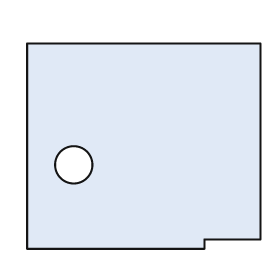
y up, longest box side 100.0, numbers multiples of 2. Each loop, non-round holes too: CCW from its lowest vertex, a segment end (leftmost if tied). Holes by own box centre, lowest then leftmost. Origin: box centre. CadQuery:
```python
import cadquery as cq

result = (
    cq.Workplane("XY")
    .moveTo(-50.0, -44.0)
    .lineTo(26.0, -44.0)
    .lineTo(26.0, -40.0)
    .lineTo(50.0, -40.0)
    .lineTo(50.0, 44.0)
    .lineTo(-50.0, 44.0)
    .close()
    .moveTo(-30.0, -8.0)
    .circle(8.0)
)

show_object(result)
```